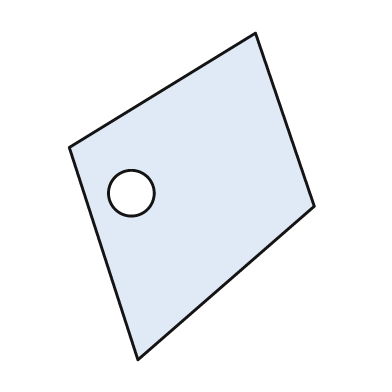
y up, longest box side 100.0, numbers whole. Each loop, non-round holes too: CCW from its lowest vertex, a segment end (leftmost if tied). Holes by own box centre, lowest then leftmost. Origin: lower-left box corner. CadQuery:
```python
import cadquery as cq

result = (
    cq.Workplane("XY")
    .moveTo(21.0, 0.0)
    .lineTo(75.0, 47.0)
    .lineTo(57.0, 100.0)
    .lineTo(0.0, 65.0)
    .close()
    .moveTo(19.0, 51.0)
    .circle(7.0)
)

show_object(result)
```